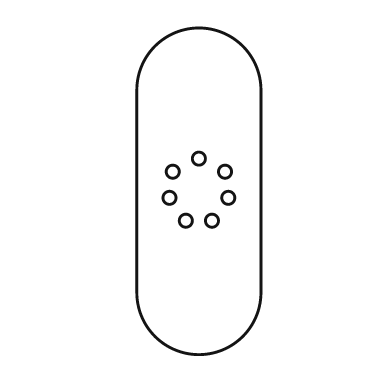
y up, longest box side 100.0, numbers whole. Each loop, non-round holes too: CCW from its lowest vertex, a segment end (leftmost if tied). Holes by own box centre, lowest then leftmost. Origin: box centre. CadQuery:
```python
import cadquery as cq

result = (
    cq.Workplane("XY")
    .moveTo(-19.0, -31.0)
    .threePointArc((0.0, -50.0), (19.0, -31.0))
    .lineTo(19.0, 31.0)
    .threePointArc((0.0, 50.0), (-19.0, 31.0))
    .close()
    .moveTo(-4.0, -9.0)
    .circle(2.0)
    .moveTo(4.0, -9.0)
    .circle(2.0)
    .moveTo(-9.0, -2.0)
    .circle(2.0)
    .moveTo(9.0, -2.0)
    .circle(2.0)
    .moveTo(-8.0, 6.0)
    .circle(2.0)
    .moveTo(8.0, 6.0)
    .circle(2.0)
    .moveTo(0.0, 10.0)
    .circle(2.0)
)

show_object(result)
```